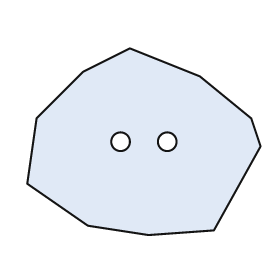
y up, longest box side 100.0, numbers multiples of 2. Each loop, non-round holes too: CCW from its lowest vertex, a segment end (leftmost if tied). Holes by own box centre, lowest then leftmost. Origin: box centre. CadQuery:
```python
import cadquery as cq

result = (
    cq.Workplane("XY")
    .moveTo(2.0, -40.0)
    .lineTo(30.0, -38.0)
    .lineTo(50.0, -2.0)
    .lineTo(46.0, 10.0)
    .lineTo(24.0, 28.0)
    .lineTo(-6.0, 40.0)
    .lineTo(-26.0, 30.0)
    .lineTo(-46.0, 10.0)
    .lineTo(-50.0, -18.0)
    .lineTo(-24.0, -36.0)
    .close()
    .moveTo(-10.0, 0.0)
    .circle(4.0)
    .moveTo(10.0, 0.0)
    .circle(4.0)
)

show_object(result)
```